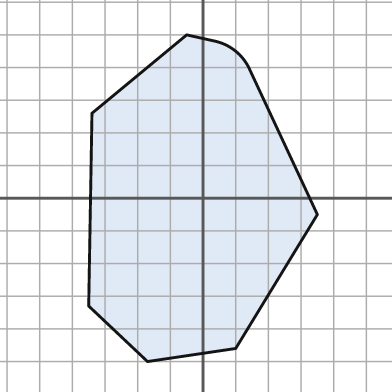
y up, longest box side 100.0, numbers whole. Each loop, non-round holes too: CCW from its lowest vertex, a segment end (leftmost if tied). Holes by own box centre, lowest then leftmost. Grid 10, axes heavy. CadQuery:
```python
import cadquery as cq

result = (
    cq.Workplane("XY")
    .moveTo(-17.0, -50.0)
    .lineTo(10.0, -46.0)
    .lineTo(35.0, -5.0)
    .lineTo(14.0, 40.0)
    .threePointArc((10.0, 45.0), (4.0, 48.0))
    .lineTo(-5.0, 50.0)
    .lineTo(-34.0, 26.0)
    .lineTo(-35.0, -33.0)
    .close()
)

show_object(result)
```